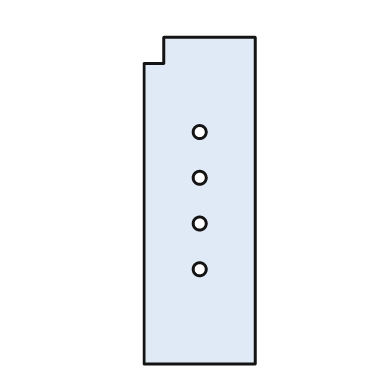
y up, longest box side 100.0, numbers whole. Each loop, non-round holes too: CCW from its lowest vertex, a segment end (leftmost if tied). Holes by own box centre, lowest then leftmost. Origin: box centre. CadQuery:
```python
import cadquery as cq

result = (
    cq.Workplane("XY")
    .moveTo(-17.0, -50.0)
    .lineTo(17.0, -50.0)
    .lineTo(17.0, 50.0)
    .lineTo(-11.0, 50.0)
    .lineTo(-11.0, 42.0)
    .lineTo(-17.0, 42.0)
    .close()
    .moveTo(0.0, -21.0)
    .circle(2.0)
    .moveTo(0.0, -7.0)
    .circle(2.0)
    .moveTo(0.0, 7.0)
    .circle(2.0)
    .moveTo(0.0, 21.0)
    .circle(2.0)
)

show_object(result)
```